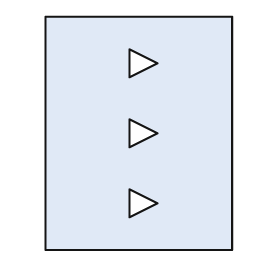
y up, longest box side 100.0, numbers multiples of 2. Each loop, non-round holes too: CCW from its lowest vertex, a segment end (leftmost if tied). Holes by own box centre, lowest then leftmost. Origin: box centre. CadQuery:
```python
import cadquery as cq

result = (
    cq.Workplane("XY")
    .moveTo(-40.0, -50.0)
    .lineTo(40.0, -50.0)
    .lineTo(40.0, 50.0)
    .lineTo(-40.0, 50.0)
    .close()
    .moveTo(-4.0, -36.0)
    .lineTo(8.0, -30.0)
    .lineTo(-4.0, -24.0)
    .close()
    .moveTo(-4.0, -6.0)
    .lineTo(8.0, 0.0)
    .lineTo(-4.0, 6.0)
    .close()
    .moveTo(-4.0, 24.0)
    .lineTo(8.0, 30.0)
    .lineTo(-4.0, 36.0)
    .close()
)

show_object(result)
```